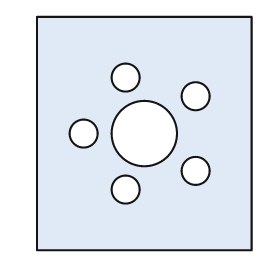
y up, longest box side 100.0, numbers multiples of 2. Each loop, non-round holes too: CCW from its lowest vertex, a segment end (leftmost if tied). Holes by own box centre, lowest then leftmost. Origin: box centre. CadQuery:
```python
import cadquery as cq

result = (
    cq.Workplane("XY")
    .moveTo(-46.0, -50.0)
    .lineTo(46.0, -50.0)
    .lineTo(46.0, 50.0)
    .lineTo(-46.0, 50.0)
    .close()
    .moveTo(-8.0, -24.0)
    .circle(6.0)
    .moveTo(22.0, -16.0)
    .circle(6.0)
    .moveTo(-26.0, 0.0)
    .circle(6.0)
    .moveTo(0.0, 0.0)
    .circle(14.0)
    .moveTo(22.0, 16.0)
    .circle(6.0)
    .moveTo(-8.0, 24.0)
    .circle(6.0)
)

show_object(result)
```